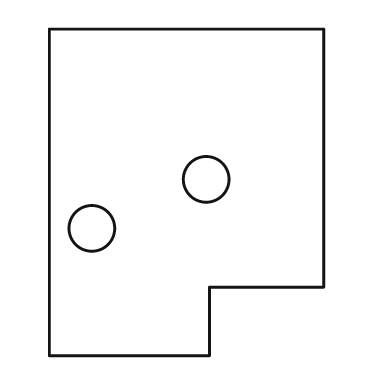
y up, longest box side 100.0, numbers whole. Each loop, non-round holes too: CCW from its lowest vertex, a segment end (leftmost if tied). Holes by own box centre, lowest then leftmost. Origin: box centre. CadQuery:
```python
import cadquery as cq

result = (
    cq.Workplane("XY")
    .moveTo(-42.0, -50.0)
    .lineTo(7.0, -50.0)
    .lineTo(7.0, -29.0)
    .lineTo(42.0, -29.0)
    .lineTo(42.0, 50.0)
    .lineTo(-42.0, 50.0)
    .close()
    .moveTo(-29.0, -11.0)
    .circle(7.0)
    .moveTo(6.0, 4.0)
    .circle(7.0)
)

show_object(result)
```